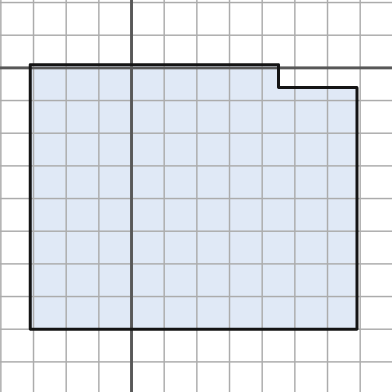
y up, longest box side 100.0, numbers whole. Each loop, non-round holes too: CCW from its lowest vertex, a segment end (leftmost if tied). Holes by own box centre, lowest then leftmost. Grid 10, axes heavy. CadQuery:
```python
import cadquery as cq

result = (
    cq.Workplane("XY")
    .moveTo(-31.0, -80.0)
    .lineTo(69.0, -80.0)
    .lineTo(69.0, -6.0)
    .lineTo(45.0, -6.0)
    .lineTo(45.0, 1.0)
    .lineTo(-31.0, 1.0)
    .close()
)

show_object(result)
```